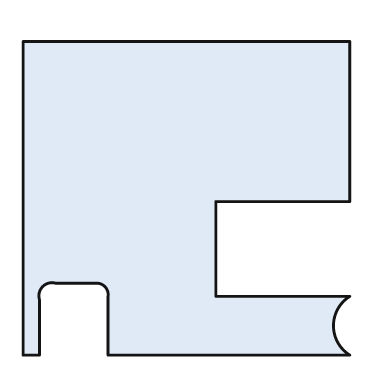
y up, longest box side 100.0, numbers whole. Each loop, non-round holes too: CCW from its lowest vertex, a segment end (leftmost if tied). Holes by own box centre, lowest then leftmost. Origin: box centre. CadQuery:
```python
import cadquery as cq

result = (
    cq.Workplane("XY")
    .moveTo(-50.0, -48.0)
    .lineTo(-45.0, -48.0)
    .lineTo(-45.0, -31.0)
    .threePointArc((-44.0, -27.0), (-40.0, -26.0))
    .lineTo(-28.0, -26.0)
    .threePointArc((-25.0, -27.0), (-24.0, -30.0))
    .lineTo(-24.0, -48.0)
    .lineTo(50.0, -48.0)
    .threePointArc((45.0, -39.0), (50.0, -30.0))
    .lineTo(9.0, -30.0)
    .lineTo(9.0, -1.0)
    .lineTo(50.0, -1.0)
    .lineTo(50.0, 48.0)
    .lineTo(-50.0, 48.0)
    .close()
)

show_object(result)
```